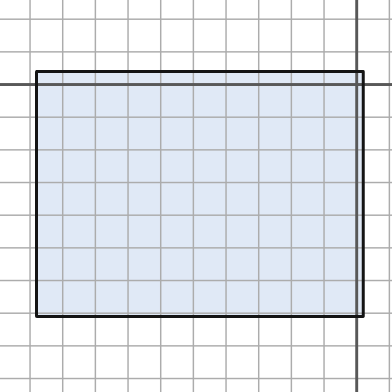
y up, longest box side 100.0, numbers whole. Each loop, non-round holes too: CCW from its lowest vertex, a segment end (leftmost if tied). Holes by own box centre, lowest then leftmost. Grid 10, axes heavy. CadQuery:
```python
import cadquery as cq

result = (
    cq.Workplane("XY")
    .moveTo(-98.0, -71.0)
    .lineTo(2.0, -71.0)
    .lineTo(2.0, 4.0)
    .lineTo(-98.0, 4.0)
    .close()
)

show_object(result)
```